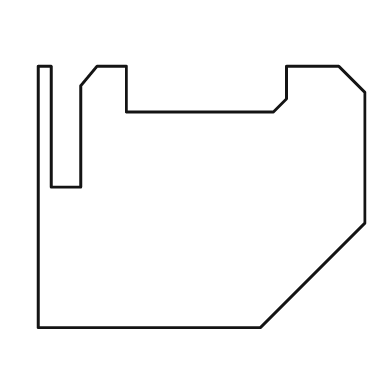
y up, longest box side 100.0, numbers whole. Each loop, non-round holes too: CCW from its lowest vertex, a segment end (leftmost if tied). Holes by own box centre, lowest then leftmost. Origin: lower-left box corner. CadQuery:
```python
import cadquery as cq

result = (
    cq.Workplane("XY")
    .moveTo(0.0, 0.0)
    .lineTo(68.0, 0.0)
    .lineTo(100.0, 32.0)
    .lineTo(100.0, 72.0)
    .lineTo(92.0, 80.0)
    .lineTo(76.0, 80.0)
    .lineTo(76.0, 70.0)
    .lineTo(72.0, 66.0)
    .lineTo(27.0, 66.0)
    .lineTo(27.0, 80.0)
    .lineTo(18.0, 80.0)
    .lineTo(13.0, 74.0)
    .lineTo(13.0, 43.0)
    .lineTo(4.0, 43.0)
    .lineTo(4.0, 80.0)
    .lineTo(0.0, 80.0)
    .close()
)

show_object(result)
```